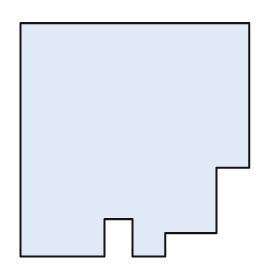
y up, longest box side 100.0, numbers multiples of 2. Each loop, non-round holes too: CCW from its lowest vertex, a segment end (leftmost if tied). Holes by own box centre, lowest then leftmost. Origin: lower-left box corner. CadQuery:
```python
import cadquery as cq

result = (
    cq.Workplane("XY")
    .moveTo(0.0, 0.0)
    .lineTo(36.0, 0.0)
    .lineTo(36.0, 16.0)
    .lineTo(48.0, 16.0)
    .lineTo(48.0, 0.0)
    .lineTo(62.0, 0.0)
    .lineTo(62.0, 10.0)
    .lineTo(84.0, 10.0)
    .lineTo(84.0, 38.0)
    .lineTo(98.0, 38.0)
    .lineTo(98.0, 100.0)
    .lineTo(0.0, 100.0)
    .close()
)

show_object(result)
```